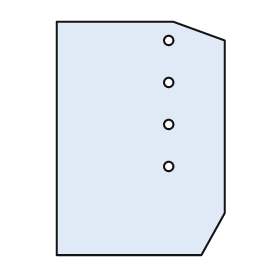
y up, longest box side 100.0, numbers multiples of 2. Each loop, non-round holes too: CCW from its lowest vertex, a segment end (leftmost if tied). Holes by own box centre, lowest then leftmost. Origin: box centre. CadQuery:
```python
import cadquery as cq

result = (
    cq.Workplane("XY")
    .moveTo(-36.0, -50.0)
    .lineTo(26.0, -50.0)
    .lineTo(36.0, -32.0)
    .lineTo(36.0, 42.0)
    .lineTo(14.0, 50.0)
    .lineTo(-36.0, 50.0)
    .close()
    .moveTo(12.0, -12.0)
    .circle(2.0)
    .moveTo(12.0, 6.0)
    .circle(2.0)
    .moveTo(12.0, 24.0)
    .circle(2.0)
    .moveTo(12.0, 42.0)
    .circle(2.0)
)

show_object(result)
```